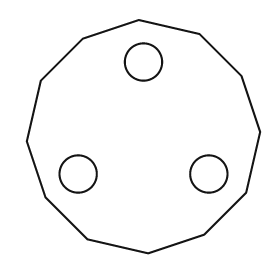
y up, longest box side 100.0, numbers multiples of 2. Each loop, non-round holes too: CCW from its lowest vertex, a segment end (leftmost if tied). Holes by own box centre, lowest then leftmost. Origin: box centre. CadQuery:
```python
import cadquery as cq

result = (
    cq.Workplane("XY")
    .moveTo(2.0, -50.0)
    .lineTo(26.0, -42.0)
    .lineTo(44.0, -24.0)
    .lineTo(50.0, 2.0)
    .lineTo(42.0, 26.0)
    .lineTo(24.0, 44.0)
    .lineTo(-2.0, 50.0)
    .lineTo(-26.0, 42.0)
    .lineTo(-44.0, 24.0)
    .lineTo(-50.0, -2.0)
    .lineTo(-42.0, -26.0)
    .lineTo(-24.0, -44.0)
    .close()
    .moveTo(-28.0, -16.0)
    .circle(8.0)
    .moveTo(28.0, -16.0)
    .circle(8.0)
    .moveTo(0.0, 32.0)
    .circle(8.0)
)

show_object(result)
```